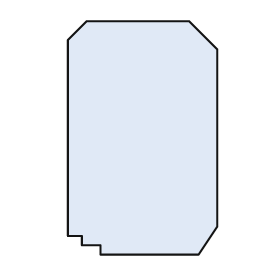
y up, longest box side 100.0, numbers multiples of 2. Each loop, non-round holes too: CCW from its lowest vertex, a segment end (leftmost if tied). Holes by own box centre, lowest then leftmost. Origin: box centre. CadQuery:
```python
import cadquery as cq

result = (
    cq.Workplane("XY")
    .moveTo(-18.0, -50.0)
    .lineTo(24.0, -50.0)
    .lineTo(32.0, -38.0)
    .lineTo(32.0, 38.0)
    .lineTo(20.0, 50.0)
    .lineTo(-24.0, 50.0)
    .lineTo(-32.0, 42.0)
    .lineTo(-32.0, -42.0)
    .lineTo(-26.0, -42.0)
    .lineTo(-26.0, -46.0)
    .lineTo(-18.0, -46.0)
    .close()
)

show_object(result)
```